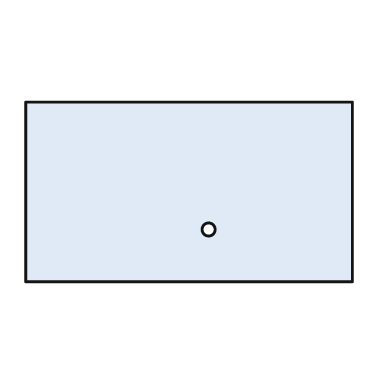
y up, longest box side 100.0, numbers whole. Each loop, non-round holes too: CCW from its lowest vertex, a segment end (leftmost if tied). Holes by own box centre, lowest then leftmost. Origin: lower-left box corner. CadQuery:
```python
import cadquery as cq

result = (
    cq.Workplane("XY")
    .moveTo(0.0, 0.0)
    .lineTo(100.0, 0.0)
    .lineTo(100.0, 55.0)
    .lineTo(0.0, 55.0)
    .close()
    .moveTo(56.0, 16.0)
    .circle(2.0)
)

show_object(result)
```